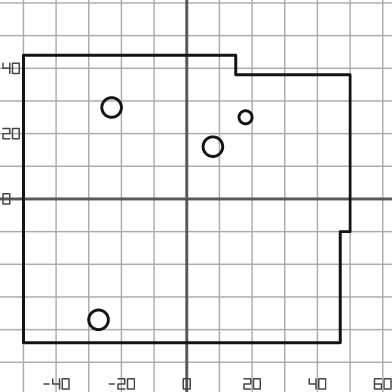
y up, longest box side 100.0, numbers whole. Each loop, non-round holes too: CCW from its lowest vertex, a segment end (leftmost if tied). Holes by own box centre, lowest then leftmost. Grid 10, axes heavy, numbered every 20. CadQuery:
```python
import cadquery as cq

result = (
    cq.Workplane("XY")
    .moveTo(-50.0, -44.0)
    .lineTo(47.0, -44.0)
    .lineTo(47.0, -10.0)
    .lineTo(50.0, -10.0)
    .lineTo(50.0, 38.0)
    .lineTo(15.0, 38.0)
    .lineTo(15.0, 44.0)
    .lineTo(-50.0, 44.0)
    .close()
    .moveTo(-27.0, -37.0)
    .circle(3.0)
    .moveTo(8.0, 16.0)
    .circle(3.0)
    .moveTo(18.0, 25.0)
    .circle(2.0)
    .moveTo(-23.0, 28.0)
    .circle(3.0)
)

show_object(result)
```